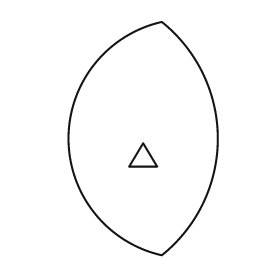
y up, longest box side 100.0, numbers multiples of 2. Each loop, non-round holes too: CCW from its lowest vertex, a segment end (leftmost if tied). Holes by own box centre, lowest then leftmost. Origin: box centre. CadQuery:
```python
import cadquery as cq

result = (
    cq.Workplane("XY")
    .moveTo(8.0, -50.0)
    .threePointArc((32.0, 0.0), (8.0, 50.0))
    .threePointArc((-32.0, 0.0), (8.0, -50.0))
    .close()
    .moveTo(-6.0, -12.0)
    .lineTo(6.0, -12.0)
    .lineTo(0.0, -2.0)
    .close()
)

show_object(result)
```